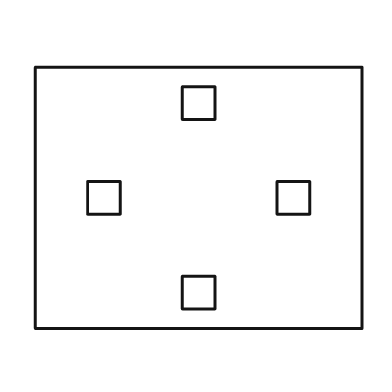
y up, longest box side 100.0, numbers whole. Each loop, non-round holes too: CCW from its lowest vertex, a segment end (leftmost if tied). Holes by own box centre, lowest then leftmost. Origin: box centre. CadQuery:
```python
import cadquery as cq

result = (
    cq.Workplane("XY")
    .moveTo(-50.0, -40.0)
    .lineTo(50.0, -40.0)
    .lineTo(50.0, 40.0)
    .lineTo(-50.0, 40.0)
    .close()
    .moveTo(-5.0, -34.0)
    .lineTo(5.0, -34.0)
    .lineTo(5.0, -24.0)
    .lineTo(-5.0, -24.0)
    .close()
    .moveTo(-34.0, -5.0)
    .lineTo(-24.0, -5.0)
    .lineTo(-24.0, 5.0)
    .lineTo(-34.0, 5.0)
    .close()
    .moveTo(24.0, -5.0)
    .lineTo(34.0, -5.0)
    .lineTo(34.0, 5.0)
    .lineTo(24.0, 5.0)
    .close()
    .moveTo(-5.0, 24.0)
    .lineTo(5.0, 24.0)
    .lineTo(5.0, 34.0)
    .lineTo(-5.0, 34.0)
    .close()
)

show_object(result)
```